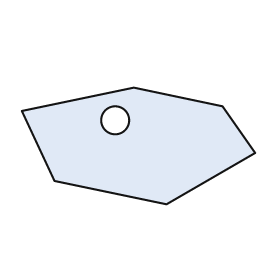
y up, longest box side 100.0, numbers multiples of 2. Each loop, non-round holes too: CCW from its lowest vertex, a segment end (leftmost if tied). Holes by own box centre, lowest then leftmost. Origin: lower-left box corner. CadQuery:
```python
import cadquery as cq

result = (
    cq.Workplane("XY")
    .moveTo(62.0, 0.0)
    .lineTo(100.0, 22.0)
    .lineTo(86.0, 42.0)
    .lineTo(48.0, 50.0)
    .lineTo(0.0, 40.0)
    .lineTo(14.0, 10.0)
    .close()
    .moveTo(40.0, 36.0)
    .circle(6.0)
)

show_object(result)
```